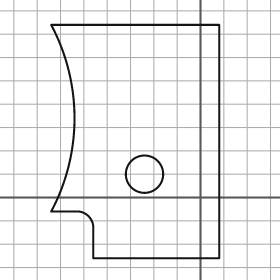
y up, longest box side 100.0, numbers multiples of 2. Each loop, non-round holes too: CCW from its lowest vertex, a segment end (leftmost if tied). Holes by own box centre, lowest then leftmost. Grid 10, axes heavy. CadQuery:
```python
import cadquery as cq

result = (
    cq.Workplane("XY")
    .moveTo(-46.0, -26.0)
    .lineTo(8.0, -26.0)
    .lineTo(8.0, 74.0)
    .lineTo(-64.0, 74.0)
    .threePointArc((-54.0, 34.0), (-64.0, -6.0))
    .lineTo(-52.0, -6.0)
    .threePointArc((-48.0, -8.0), (-46.0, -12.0))
    .close()
    .moveTo(-24.0, 10.0)
    .circle(8.0)
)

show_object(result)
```